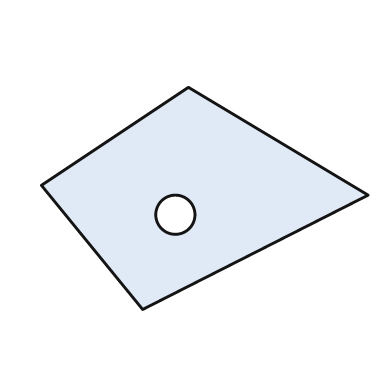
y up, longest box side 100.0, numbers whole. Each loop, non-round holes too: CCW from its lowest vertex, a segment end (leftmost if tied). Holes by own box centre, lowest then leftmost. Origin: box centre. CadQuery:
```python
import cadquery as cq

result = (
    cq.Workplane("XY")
    .moveTo(-19.0, -34.0)
    .lineTo(50.0, 1.0)
    .lineTo(-5.0, 34.0)
    .lineTo(-50.0, 4.0)
    .close()
    .moveTo(-9.0, -5.0)
    .circle(6.0)
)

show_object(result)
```